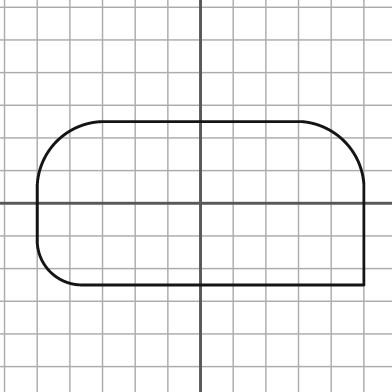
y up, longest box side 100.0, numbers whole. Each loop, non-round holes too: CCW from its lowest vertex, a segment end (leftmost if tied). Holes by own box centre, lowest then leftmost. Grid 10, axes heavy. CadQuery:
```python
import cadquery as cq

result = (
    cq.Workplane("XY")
    .moveTo(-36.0, -25.0)
    .lineTo(50.0, -25.0)
    .lineTo(50.0, 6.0)
    .threePointArc((44.0, 19.0), (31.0, 25.0))
    .lineTo(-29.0, 25.0)
    .threePointArc((-44.0, 19.0), (-50.0, 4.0))
    .lineTo(-50.0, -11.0)
    .threePointArc((-46.0, -21.0), (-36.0, -25.0))
    .close()
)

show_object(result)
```